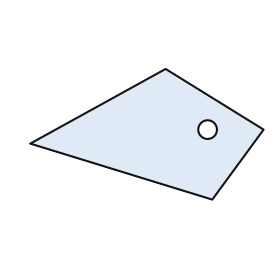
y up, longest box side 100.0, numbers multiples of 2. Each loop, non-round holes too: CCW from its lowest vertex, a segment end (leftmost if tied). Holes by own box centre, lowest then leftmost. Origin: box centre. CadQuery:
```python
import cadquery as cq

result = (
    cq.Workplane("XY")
    .moveTo(28.0, -28.0)
    .lineTo(50.0, 2.0)
    .lineTo(8.0, 28.0)
    .lineTo(-50.0, -4.0)
    .close()
    .moveTo(26.0, 2.0)
    .circle(4.0)
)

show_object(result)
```